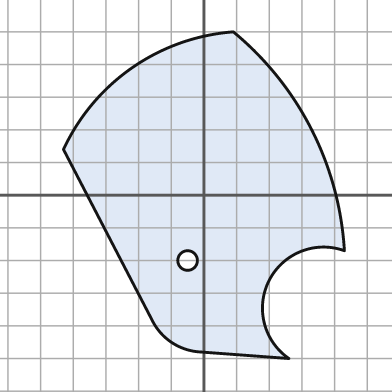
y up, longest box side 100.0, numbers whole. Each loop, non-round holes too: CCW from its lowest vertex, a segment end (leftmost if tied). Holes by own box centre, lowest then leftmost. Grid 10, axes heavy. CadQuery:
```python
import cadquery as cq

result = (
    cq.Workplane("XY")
    .moveTo(26.0, -50.0)
    .threePointArc((20.0, -26.0), (43.0, -17.0))
    .threePointArc((33.0, 20.0), (9.0, 50.0))
    .threePointArc((-22.0, 39.0), (-43.0, 14.0))
    .lineTo(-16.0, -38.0)
    .threePointArc((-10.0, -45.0), (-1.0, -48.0))
    .close()
    .moveTo(-5.0, -20.0)
    .circle(3.0)
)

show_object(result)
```